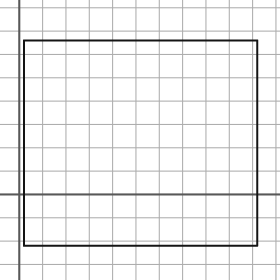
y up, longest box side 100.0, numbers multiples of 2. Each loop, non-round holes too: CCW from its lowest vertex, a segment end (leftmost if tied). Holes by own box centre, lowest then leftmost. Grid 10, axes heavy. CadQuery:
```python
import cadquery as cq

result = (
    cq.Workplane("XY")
    .moveTo(2.0, -22.0)
    .lineTo(102.0, -22.0)
    .lineTo(102.0, 66.0)
    .lineTo(2.0, 66.0)
    .close()
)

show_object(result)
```